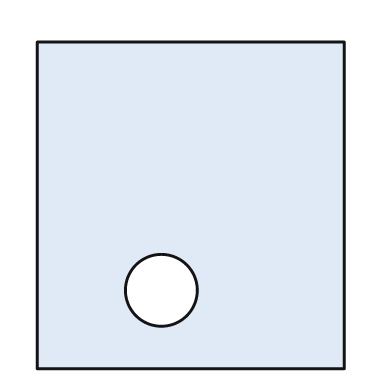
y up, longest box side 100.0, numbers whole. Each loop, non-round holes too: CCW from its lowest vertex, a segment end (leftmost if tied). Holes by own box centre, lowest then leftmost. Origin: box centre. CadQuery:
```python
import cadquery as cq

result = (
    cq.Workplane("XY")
    .moveTo(-47.0, -50.0)
    .lineTo(47.0, -50.0)
    .lineTo(47.0, 50.0)
    .lineTo(-47.0, 50.0)
    .close()
    .moveTo(-9.0, -26.0)
    .circle(11.0)
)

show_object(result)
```